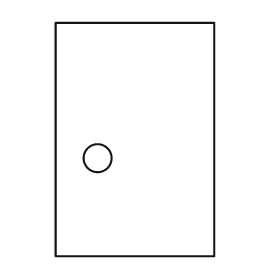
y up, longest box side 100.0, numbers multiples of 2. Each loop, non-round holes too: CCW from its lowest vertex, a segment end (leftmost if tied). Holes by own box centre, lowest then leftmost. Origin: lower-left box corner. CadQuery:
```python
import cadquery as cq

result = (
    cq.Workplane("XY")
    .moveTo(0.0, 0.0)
    .lineTo(68.0, 0.0)
    .lineTo(68.0, 100.0)
    .lineTo(0.0, 100.0)
    .close()
    .moveTo(18.0, 42.0)
    .circle(6.0)
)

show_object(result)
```